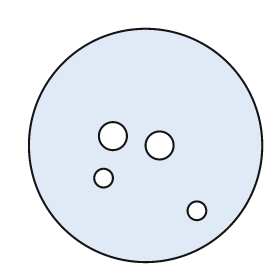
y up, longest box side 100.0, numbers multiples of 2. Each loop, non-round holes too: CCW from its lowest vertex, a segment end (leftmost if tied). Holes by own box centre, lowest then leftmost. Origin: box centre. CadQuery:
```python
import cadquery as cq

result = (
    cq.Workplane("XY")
    .moveTo(0.0, 0.0)
    .circle(50.0)
    .moveTo(22.0, -28.0)
    .circle(4.0)
    .moveTo(-18.0, -14.0)
    .circle(4.0)
    .moveTo(6.0, 0.0)
    .circle(6.0)
    .moveTo(-14.0, 4.0)
    .circle(6.0)
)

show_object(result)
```